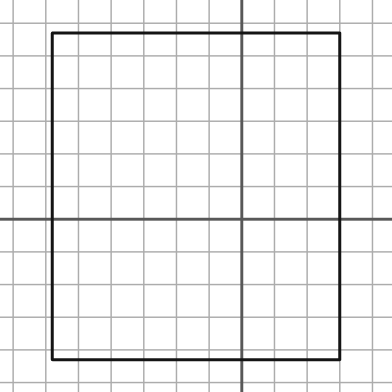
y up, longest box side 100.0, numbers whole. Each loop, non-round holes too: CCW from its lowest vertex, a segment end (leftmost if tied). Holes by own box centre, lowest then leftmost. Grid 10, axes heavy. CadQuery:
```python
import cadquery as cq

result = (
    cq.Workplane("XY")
    .moveTo(-58.0, -43.0)
    .lineTo(30.0, -43.0)
    .lineTo(30.0, 57.0)
    .lineTo(-58.0, 57.0)
    .close()
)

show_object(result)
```